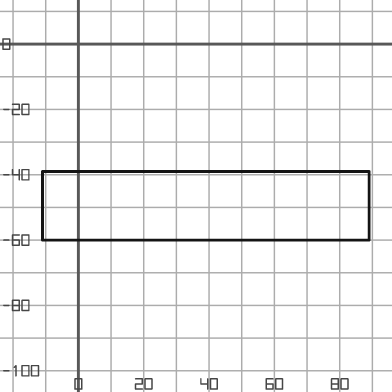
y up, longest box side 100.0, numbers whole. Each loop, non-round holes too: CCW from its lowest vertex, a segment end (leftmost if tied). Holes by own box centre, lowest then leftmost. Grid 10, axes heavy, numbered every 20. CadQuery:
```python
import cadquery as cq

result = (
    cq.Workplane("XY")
    .moveTo(-11.0, -60.0)
    .lineTo(89.0, -60.0)
    .lineTo(89.0, -39.0)
    .lineTo(-11.0, -39.0)
    .close()
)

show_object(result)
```